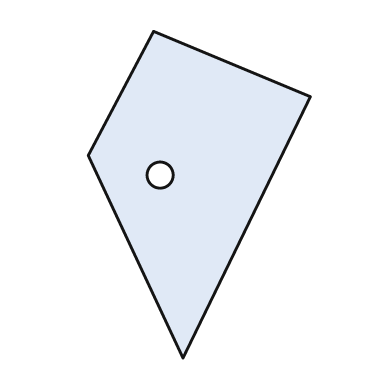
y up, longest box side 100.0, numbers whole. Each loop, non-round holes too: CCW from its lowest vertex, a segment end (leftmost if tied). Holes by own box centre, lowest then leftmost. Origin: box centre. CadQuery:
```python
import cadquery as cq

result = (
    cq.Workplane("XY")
    .moveTo(-5.0, -50.0)
    .lineTo(34.0, 30.0)
    .lineTo(-14.0, 50.0)
    .lineTo(-34.0, 12.0)
    .close()
    .moveTo(-12.0, 6.0)
    .circle(4.0)
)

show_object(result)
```